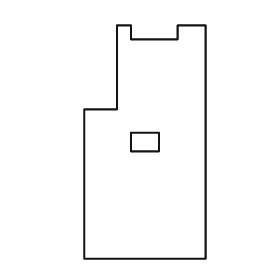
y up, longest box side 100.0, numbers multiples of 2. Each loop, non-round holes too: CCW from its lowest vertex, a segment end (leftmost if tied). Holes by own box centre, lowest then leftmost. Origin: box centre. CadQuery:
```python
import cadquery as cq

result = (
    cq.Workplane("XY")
    .moveTo(-26.0, -50.0)
    .lineTo(26.0, -50.0)
    .lineTo(26.0, 50.0)
    .lineTo(14.0, 50.0)
    .lineTo(14.0, 44.0)
    .lineTo(-6.0, 44.0)
    .lineTo(-6.0, 50.0)
    .lineTo(-12.0, 50.0)
    .lineTo(-12.0, 14.0)
    .lineTo(-26.0, 14.0)
    .close()
    .moveTo(-6.0, -4.0)
    .lineTo(6.0, -4.0)
    .lineTo(6.0, 4.0)
    .lineTo(-6.0, 4.0)
    .close()
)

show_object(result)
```